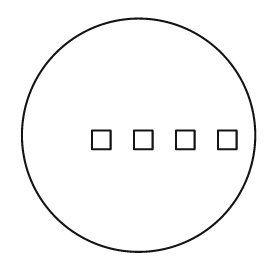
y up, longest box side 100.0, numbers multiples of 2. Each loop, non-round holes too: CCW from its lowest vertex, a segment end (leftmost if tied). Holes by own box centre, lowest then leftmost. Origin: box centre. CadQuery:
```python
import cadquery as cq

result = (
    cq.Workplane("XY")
    .moveTo(0.0, 0.0)
    .circle(50.0)
    .moveTo(-20.0, -6.0)
    .lineTo(-12.0, -6.0)
    .lineTo(-12.0, 2.0)
    .lineTo(-20.0, 2.0)
    .close()
    .moveTo(-2.0, -6.0)
    .lineTo(6.0, -6.0)
    .lineTo(6.0, 2.0)
    .lineTo(-2.0, 2.0)
    .close()
    .moveTo(16.0, -6.0)
    .lineTo(24.0, -6.0)
    .lineTo(24.0, 2.0)
    .lineTo(16.0, 2.0)
    .close()
    .moveTo(34.0, -6.0)
    .lineTo(42.0, -6.0)
    .lineTo(42.0, 2.0)
    .lineTo(34.0, 2.0)
    .close()
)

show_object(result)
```